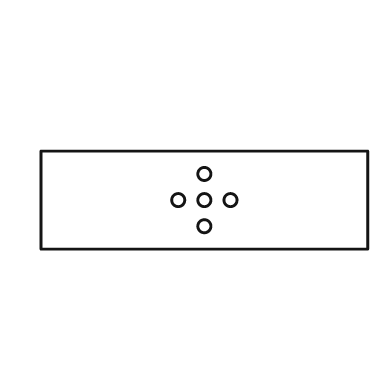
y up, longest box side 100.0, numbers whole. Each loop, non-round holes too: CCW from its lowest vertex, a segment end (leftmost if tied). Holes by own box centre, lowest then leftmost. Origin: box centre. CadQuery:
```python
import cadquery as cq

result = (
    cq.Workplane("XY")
    .moveTo(-50.0, -15.0)
    .lineTo(50.0, -15.0)
    .lineTo(50.0, 15.0)
    .lineTo(-50.0, 15.0)
    .close()
    .moveTo(0.0, -8.0)
    .circle(2.0)
    .moveTo(-8.0, 0.0)
    .circle(2.0)
    .moveTo(0.0, 0.0)
    .circle(2.0)
    .moveTo(8.0, 0.0)
    .circle(2.0)
    .moveTo(0.0, 8.0)
    .circle(2.0)
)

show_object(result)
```